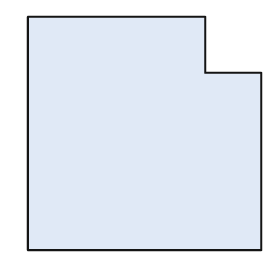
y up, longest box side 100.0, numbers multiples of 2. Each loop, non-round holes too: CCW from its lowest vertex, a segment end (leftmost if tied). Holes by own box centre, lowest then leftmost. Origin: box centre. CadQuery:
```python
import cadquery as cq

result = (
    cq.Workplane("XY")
    .moveTo(-50.0, -50.0)
    .lineTo(50.0, -50.0)
    .lineTo(50.0, 26.0)
    .lineTo(26.0, 26.0)
    .lineTo(26.0, 50.0)
    .lineTo(-50.0, 50.0)
    .close()
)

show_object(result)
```